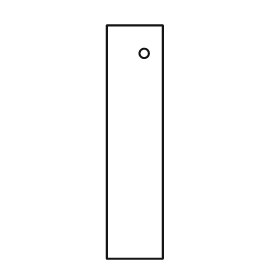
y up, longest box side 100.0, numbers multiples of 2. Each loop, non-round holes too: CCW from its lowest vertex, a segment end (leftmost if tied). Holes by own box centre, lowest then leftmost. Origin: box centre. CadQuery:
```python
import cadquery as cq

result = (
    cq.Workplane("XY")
    .moveTo(-12.0, -50.0)
    .lineTo(12.0, -50.0)
    .lineTo(12.0, 50.0)
    .lineTo(-12.0, 50.0)
    .close()
    .moveTo(4.0, 38.0)
    .circle(2.0)
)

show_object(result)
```